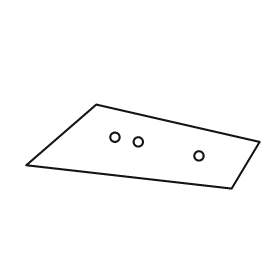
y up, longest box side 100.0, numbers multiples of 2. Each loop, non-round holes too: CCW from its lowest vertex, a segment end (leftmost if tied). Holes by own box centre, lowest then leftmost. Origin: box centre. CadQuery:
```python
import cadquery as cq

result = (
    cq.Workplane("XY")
    .moveTo(38.0, -18.0)
    .lineTo(50.0, 2.0)
    .lineTo(-20.0, 18.0)
    .lineTo(-50.0, -8.0)
    .close()
    .moveTo(24.0, -4.0)
    .circle(2.0)
    .moveTo(-2.0, 2.0)
    .circle(2.0)
    .moveTo(-12.0, 4.0)
    .circle(2.0)
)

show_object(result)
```